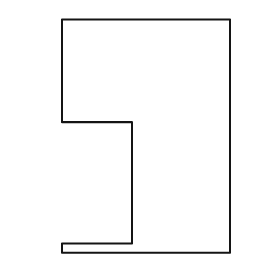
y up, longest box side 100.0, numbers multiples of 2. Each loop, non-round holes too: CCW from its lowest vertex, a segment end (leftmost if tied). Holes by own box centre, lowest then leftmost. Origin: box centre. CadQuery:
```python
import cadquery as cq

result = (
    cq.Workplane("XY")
    .moveTo(-36.0, -50.0)
    .lineTo(36.0, -50.0)
    .lineTo(36.0, 50.0)
    .lineTo(-36.0, 50.0)
    .lineTo(-36.0, 6.0)
    .lineTo(-6.0, 6.0)
    .lineTo(-6.0, -46.0)
    .lineTo(-36.0, -46.0)
    .close()
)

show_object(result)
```